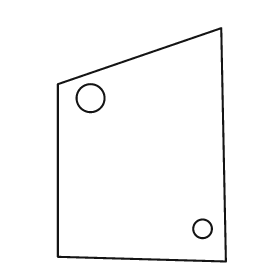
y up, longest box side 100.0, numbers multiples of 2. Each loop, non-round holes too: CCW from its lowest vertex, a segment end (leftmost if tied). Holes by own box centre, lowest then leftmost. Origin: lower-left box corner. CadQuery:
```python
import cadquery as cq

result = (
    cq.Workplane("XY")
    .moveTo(72.0, 0.0)
    .lineTo(70.0, 100.0)
    .lineTo(0.0, 76.0)
    .lineTo(0.0, 2.0)
    .close()
    .moveTo(62.0, 14.0)
    .circle(4.0)
    .moveTo(14.0, 70.0)
    .circle(6.0)
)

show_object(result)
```